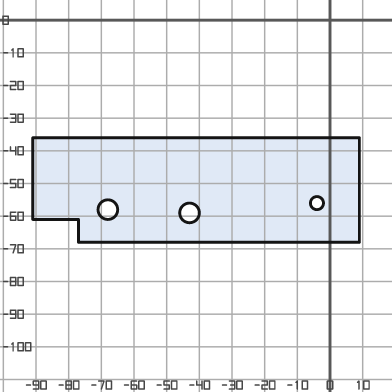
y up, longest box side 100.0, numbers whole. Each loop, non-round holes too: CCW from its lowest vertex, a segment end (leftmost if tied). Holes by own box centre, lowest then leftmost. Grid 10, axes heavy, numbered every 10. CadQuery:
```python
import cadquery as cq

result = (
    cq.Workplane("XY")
    .moveTo(-77.0, -68.0)
    .lineTo(9.0, -68.0)
    .lineTo(9.0, -36.0)
    .lineTo(-91.0, -36.0)
    .lineTo(-91.0, -61.0)
    .lineTo(-77.0, -61.0)
    .close()
    .moveTo(-43.0, -59.0)
    .circle(3.0)
    .moveTo(-68.0, -58.0)
    .circle(3.0)
    .moveTo(-4.0, -56.0)
    .circle(2.0)
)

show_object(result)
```